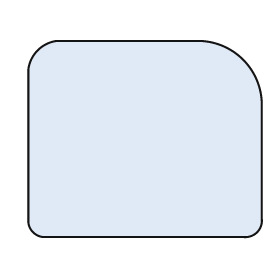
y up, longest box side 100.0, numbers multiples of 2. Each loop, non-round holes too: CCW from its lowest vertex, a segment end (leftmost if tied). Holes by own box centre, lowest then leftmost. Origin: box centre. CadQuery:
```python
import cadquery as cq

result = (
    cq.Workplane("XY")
    .moveTo(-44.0, -42.0)
    .lineTo(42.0, -42.0)
    .threePointArc((48.0, -40.0), (50.0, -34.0))
    .lineTo(50.0, 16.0)
    .threePointArc((42.0, 34.0), (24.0, 42.0))
    .lineTo(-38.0, 42.0)
    .threePointArc((-46.0, 38.0), (-50.0, 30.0))
    .lineTo(-50.0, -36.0)
    .threePointArc((-48.0, -40.0), (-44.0, -42.0))
    .close()
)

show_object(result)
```